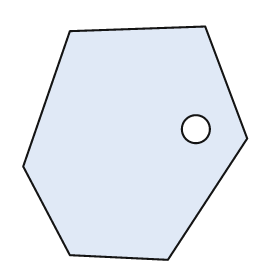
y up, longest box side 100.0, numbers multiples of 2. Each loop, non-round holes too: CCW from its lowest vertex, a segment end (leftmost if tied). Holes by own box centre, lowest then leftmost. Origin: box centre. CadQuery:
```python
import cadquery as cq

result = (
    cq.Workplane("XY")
    .moveTo(14.0, -50.0)
    .lineTo(48.0, 2.0)
    .lineTo(30.0, 50.0)
    .lineTo(-28.0, 48.0)
    .lineTo(-48.0, -10.0)
    .lineTo(-28.0, -48.0)
    .close()
    .moveTo(26.0, 6.0)
    .circle(6.0)
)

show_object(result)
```